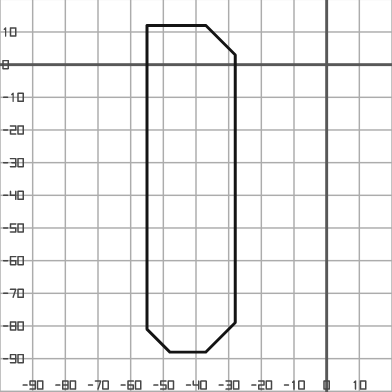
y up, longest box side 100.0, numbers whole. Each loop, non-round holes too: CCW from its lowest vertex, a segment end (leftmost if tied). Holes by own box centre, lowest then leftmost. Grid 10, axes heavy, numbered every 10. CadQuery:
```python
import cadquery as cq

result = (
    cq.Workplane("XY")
    .moveTo(-48.0, -88.0)
    .lineTo(-37.0, -88.0)
    .lineTo(-28.0, -79.0)
    .lineTo(-28.0, 3.0)
    .lineTo(-37.0, 12.0)
    .lineTo(-55.0, 12.0)
    .lineTo(-55.0, -81.0)
    .close()
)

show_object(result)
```